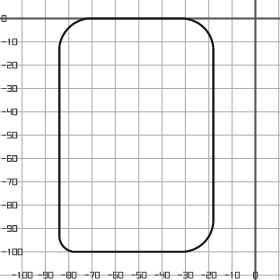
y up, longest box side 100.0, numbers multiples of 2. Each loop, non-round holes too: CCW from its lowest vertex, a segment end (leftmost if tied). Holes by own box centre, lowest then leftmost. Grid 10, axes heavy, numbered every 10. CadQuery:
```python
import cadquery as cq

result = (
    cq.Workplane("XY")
    .moveTo(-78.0, -100.0)
    .lineTo(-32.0, -100.0)
    .threePointArc((-22.0, -96.0), (-18.0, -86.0))
    .lineTo(-18.0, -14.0)
    .threePointArc((-22.0, -4.0), (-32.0, 0.0))
    .lineTo(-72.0, 0.0)
    .threePointArc((-80.0, -4.0), (-84.0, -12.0))
    .lineTo(-84.0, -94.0)
    .threePointArc((-82.0, -98.0), (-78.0, -100.0))
    .close()
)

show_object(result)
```